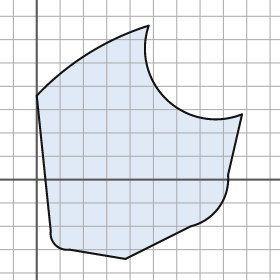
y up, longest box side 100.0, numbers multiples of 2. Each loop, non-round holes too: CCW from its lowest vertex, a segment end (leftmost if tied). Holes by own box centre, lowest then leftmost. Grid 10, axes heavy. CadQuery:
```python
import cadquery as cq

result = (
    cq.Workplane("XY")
    .moveTo(38.0, -34.0)
    .lineTo(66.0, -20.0)
    .threePointArc((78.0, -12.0), (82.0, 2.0))
    .lineTo(88.0, 28.0)
    .threePointArc((56.0, 34.0), (48.0, 66.0))
    .threePointArc((22.0, 54.0), (0.0, 36.0))
    .lineTo(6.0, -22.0)
    .threePointArc((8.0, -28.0), (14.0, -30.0))
    .close()
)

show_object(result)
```